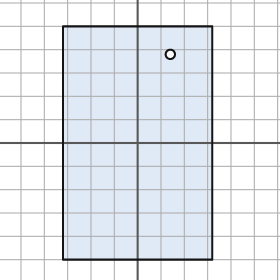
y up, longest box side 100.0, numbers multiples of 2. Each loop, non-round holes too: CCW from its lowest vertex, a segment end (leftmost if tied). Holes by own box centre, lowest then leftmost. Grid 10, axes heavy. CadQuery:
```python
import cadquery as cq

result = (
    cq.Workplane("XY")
    .moveTo(-32.0, -50.0)
    .lineTo(32.0, -50.0)
    .lineTo(32.0, 50.0)
    .lineTo(-32.0, 50.0)
    .close()
    .moveTo(14.0, 38.0)
    .circle(2.0)
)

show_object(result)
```